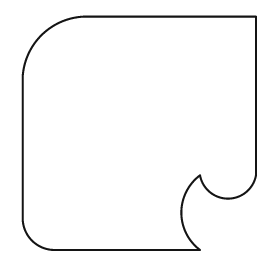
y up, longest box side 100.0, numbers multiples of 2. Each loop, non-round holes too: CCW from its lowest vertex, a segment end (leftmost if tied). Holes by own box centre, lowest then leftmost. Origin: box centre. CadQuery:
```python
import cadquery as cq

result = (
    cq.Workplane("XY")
    .moveTo(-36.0, -50.0)
    .lineTo(26.0, -50.0)
    .threePointArc((18.0, -34.0), (26.0, -18.0))
    .threePointArc((38.0, -28.0), (50.0, -18.0))
    .lineTo(50.0, 50.0)
    .lineTo(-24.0, 50.0)
    .threePointArc((-42.0, 42.0), (-50.0, 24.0))
    .lineTo(-50.0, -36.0)
    .threePointArc((-46.0, -46.0), (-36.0, -50.0))
    .close()
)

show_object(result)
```